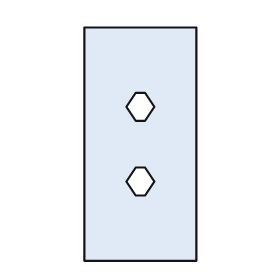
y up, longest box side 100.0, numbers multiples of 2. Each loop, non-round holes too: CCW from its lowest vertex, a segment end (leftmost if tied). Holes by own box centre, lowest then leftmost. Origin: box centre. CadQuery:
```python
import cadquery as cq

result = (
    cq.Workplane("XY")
    .moveTo(-24.0, -50.0)
    .lineTo(24.0, -50.0)
    .lineTo(24.0, 50.0)
    .lineTo(-24.0, 50.0)
    .close()
    .moveTo(-2.0, -22.0)
    .lineTo(2.0, -22.0)
    .lineTo(6.0, -16.0)
    .lineTo(2.0, -10.0)
    .lineTo(-2.0, -10.0)
    .lineTo(-6.0, -16.0)
    .close()
    .moveTo(-2.0, 10.0)
    .lineTo(2.0, 10.0)
    .lineTo(6.0, 16.0)
    .lineTo(2.0, 22.0)
    .lineTo(-2.0, 22.0)
    .lineTo(-6.0, 16.0)
    .close()
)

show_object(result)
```